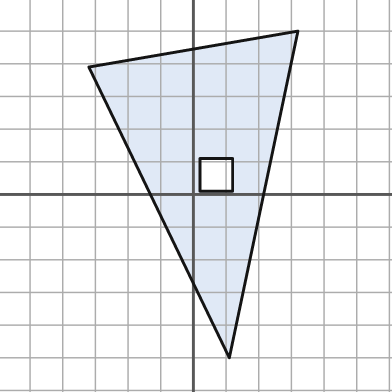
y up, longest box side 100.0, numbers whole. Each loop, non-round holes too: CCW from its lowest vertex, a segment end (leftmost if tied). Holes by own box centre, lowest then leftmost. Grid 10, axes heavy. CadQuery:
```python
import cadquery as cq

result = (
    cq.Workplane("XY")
    .moveTo(11.0, -50.0)
    .lineTo(32.0, 50.0)
    .lineTo(-32.0, 39.0)
    .close()
    .moveTo(2.0, 1.0)
    .lineTo(12.0, 1.0)
    .lineTo(12.0, 11.0)
    .lineTo(2.0, 11.0)
    .close()
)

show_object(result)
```